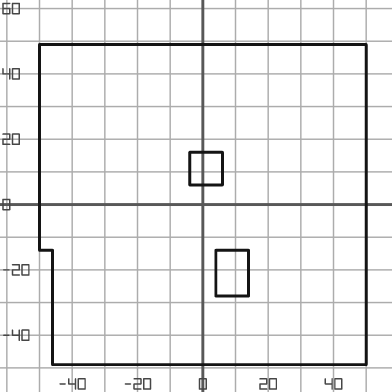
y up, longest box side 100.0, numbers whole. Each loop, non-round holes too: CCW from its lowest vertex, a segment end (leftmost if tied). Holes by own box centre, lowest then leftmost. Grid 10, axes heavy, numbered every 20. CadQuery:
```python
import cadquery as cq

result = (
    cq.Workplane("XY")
    .moveTo(-46.0, -49.0)
    .lineTo(50.0, -49.0)
    .lineTo(50.0, 49.0)
    .lineTo(-50.0, 49.0)
    .lineTo(-50.0, -14.0)
    .lineTo(-46.0, -14.0)
    .close()
    .moveTo(4.0, -28.0)
    .lineTo(14.0, -28.0)
    .lineTo(14.0, -14.0)
    .lineTo(4.0, -14.0)
    .close()
    .moveTo(-4.0, 6.0)
    .lineTo(6.0, 6.0)
    .lineTo(6.0, 16.0)
    .lineTo(-4.0, 16.0)
    .close()
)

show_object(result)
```